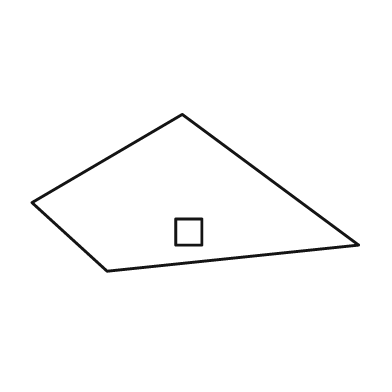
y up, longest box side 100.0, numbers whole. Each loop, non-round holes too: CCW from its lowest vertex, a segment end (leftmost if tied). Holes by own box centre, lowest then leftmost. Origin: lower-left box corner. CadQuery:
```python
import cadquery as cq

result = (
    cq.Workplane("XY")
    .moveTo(23.0, 0.0)
    .lineTo(100.0, 8.0)
    .lineTo(46.0, 48.0)
    .lineTo(0.0, 21.0)
    .close()
    .moveTo(44.0, 8.0)
    .lineTo(52.0, 8.0)
    .lineTo(52.0, 16.0)
    .lineTo(44.0, 16.0)
    .close()
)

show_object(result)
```